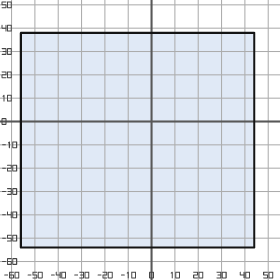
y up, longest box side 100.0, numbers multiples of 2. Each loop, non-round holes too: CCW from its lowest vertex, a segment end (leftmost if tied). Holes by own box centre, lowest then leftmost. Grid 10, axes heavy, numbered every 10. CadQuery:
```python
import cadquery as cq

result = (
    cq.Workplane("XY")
    .moveTo(-56.0, -54.0)
    .lineTo(44.0, -54.0)
    .lineTo(44.0, 38.0)
    .lineTo(-56.0, 38.0)
    .close()
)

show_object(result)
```